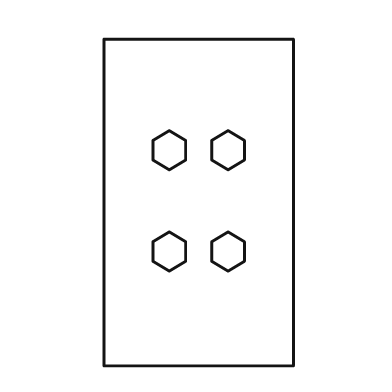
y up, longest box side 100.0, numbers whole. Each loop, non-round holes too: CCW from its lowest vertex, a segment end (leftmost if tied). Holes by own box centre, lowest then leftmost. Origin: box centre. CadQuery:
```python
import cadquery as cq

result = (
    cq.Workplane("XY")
    .moveTo(-29.0, -50.0)
    .lineTo(29.0, -50.0)
    .lineTo(29.0, 50.0)
    .lineTo(-29.0, 50.0)
    .close()
    .moveTo(-9.0, -21.0)
    .lineTo(-4.0, -18.0)
    .lineTo(-4.0, -12.0)
    .lineTo(-9.0, -9.0)
    .lineTo(-14.0, -12.0)
    .lineTo(-14.0, -18.0)
    .close()
    .moveTo(9.0, -21.0)
    .lineTo(14.0, -18.0)
    .lineTo(14.0, -12.0)
    .lineTo(9.0, -9.0)
    .lineTo(4.0, -12.0)
    .lineTo(4.0, -18.0)
    .close()
    .moveTo(-9.0, 10.0)
    .lineTo(-4.0, 13.0)
    .lineTo(-4.0, 19.0)
    .lineTo(-9.0, 22.0)
    .lineTo(-14.0, 19.0)
    .lineTo(-14.0, 13.0)
    .close()
    .moveTo(9.0, 10.0)
    .lineTo(14.0, 13.0)
    .lineTo(14.0, 19.0)
    .lineTo(9.0, 22.0)
    .lineTo(4.0, 19.0)
    .lineTo(4.0, 13.0)
    .close()
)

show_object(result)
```